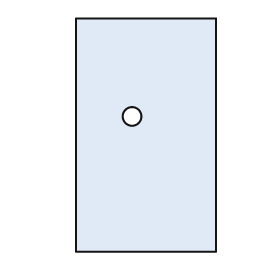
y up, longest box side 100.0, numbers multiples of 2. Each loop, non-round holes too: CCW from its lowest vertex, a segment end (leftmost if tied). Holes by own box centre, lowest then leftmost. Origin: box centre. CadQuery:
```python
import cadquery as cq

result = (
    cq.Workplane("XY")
    .moveTo(-30.0, -50.0)
    .lineTo(30.0, -50.0)
    .lineTo(30.0, 50.0)
    .lineTo(-30.0, 50.0)
    .close()
    .moveTo(-6.0, 8.0)
    .circle(4.0)
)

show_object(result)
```